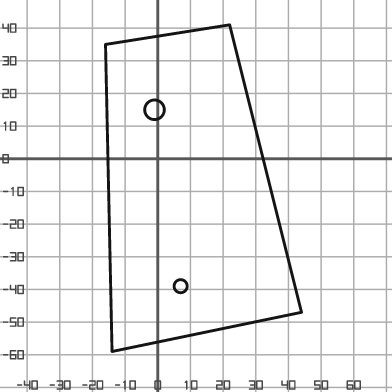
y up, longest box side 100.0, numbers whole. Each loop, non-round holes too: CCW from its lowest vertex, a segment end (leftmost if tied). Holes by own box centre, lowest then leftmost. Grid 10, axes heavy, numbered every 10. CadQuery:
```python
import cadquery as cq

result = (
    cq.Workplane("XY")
    .moveTo(-14.0, -59.0)
    .lineTo(44.0, -47.0)
    .lineTo(22.0, 41.0)
    .lineTo(-16.0, 35.0)
    .close()
    .moveTo(7.0, -39.0)
    .circle(2.0)
    .moveTo(-1.0, 15.0)
    .circle(3.0)
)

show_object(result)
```